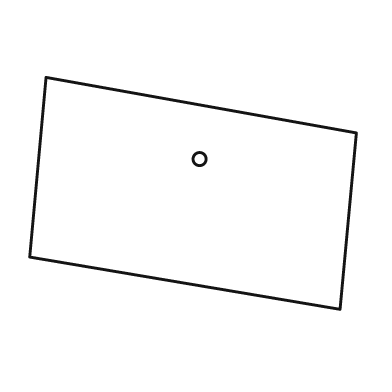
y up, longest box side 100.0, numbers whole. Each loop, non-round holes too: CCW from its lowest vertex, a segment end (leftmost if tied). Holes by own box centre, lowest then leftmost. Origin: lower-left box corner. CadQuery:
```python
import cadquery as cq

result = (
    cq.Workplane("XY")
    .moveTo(95.0, 0.0)
    .lineTo(100.0, 54.0)
    .lineTo(5.0, 71.0)
    .lineTo(0.0, 16.0)
    .close()
    .moveTo(52.0, 46.0)
    .circle(2.0)
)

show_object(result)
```